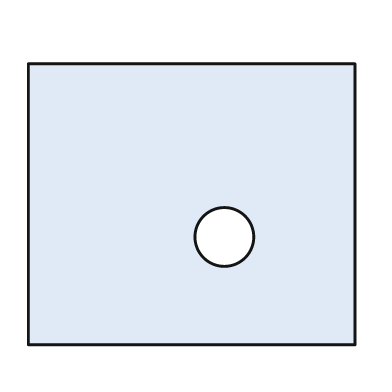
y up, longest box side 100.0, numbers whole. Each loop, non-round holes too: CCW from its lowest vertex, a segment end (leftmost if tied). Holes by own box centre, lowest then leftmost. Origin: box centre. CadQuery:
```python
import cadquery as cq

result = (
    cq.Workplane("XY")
    .moveTo(-50.0, -43.0)
    .lineTo(50.0, -43.0)
    .lineTo(50.0, 43.0)
    .lineTo(-50.0, 43.0)
    .close()
    .moveTo(10.0, -10.0)
    .circle(9.0)
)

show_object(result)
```